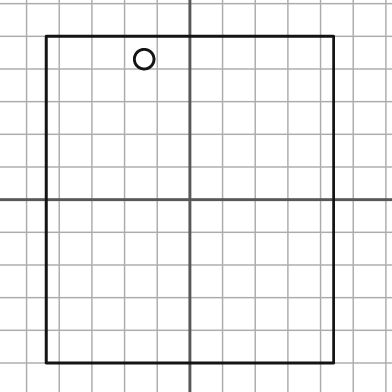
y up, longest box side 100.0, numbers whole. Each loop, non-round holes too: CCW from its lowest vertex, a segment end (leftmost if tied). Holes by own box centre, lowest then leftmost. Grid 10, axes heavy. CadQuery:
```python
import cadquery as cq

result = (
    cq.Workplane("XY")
    .moveTo(-44.0, -50.0)
    .lineTo(44.0, -50.0)
    .lineTo(44.0, 50.0)
    .lineTo(-44.0, 50.0)
    .close()
    .moveTo(-14.0, 43.0)
    .circle(3.0)
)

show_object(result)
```